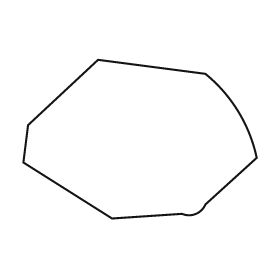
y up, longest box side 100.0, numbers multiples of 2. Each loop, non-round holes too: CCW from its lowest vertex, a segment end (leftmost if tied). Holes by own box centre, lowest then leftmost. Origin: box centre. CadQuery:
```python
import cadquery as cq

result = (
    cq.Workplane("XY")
    .moveTo(-12.0, -34.0)
    .lineTo(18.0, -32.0)
    .threePointArc((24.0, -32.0), (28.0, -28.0))
    .lineTo(50.0, -8.0)
    .threePointArc((42.0, 12.0), (28.0, 28.0))
    .lineTo(-18.0, 34.0)
    .lineTo(-48.0, 6.0)
    .lineTo(-50.0, -10.0)
    .close()
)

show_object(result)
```